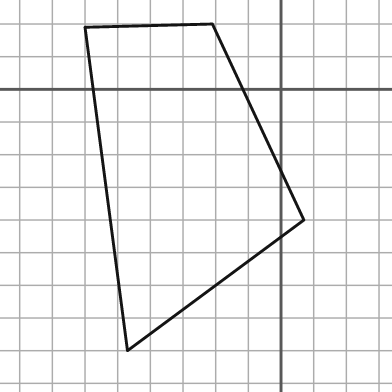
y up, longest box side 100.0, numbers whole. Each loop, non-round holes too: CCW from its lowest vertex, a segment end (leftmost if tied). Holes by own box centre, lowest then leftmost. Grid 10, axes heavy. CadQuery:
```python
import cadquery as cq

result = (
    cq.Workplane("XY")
    .moveTo(-47.0, -80.0)
    .lineTo(7.0, -40.0)
    .lineTo(-21.0, 20.0)
    .lineTo(-60.0, 19.0)
    .close()
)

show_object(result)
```